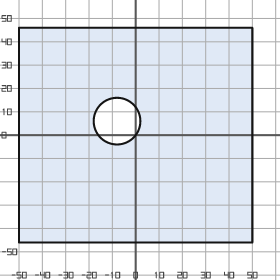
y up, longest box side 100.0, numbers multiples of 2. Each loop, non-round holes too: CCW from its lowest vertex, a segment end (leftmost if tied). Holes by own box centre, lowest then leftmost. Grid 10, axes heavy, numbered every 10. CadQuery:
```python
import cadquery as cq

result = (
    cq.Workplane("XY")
    .moveTo(-50.0, -46.0)
    .lineTo(50.0, -46.0)
    .lineTo(50.0, 46.0)
    .lineTo(-50.0, 46.0)
    .close()
    .moveTo(-8.0, 6.0)
    .circle(10.0)
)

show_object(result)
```